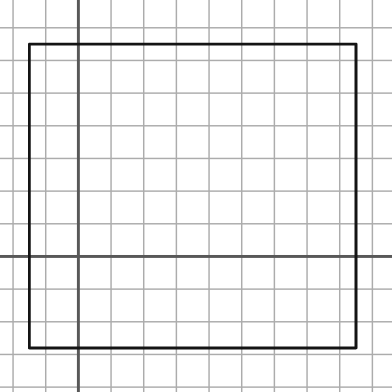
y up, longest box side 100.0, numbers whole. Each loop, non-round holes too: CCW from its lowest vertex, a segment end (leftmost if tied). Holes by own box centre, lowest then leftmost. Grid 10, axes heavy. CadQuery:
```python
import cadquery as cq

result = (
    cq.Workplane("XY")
    .moveTo(-15.0, -28.0)
    .lineTo(85.0, -28.0)
    .lineTo(85.0, 65.0)
    .lineTo(-15.0, 65.0)
    .close()
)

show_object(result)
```